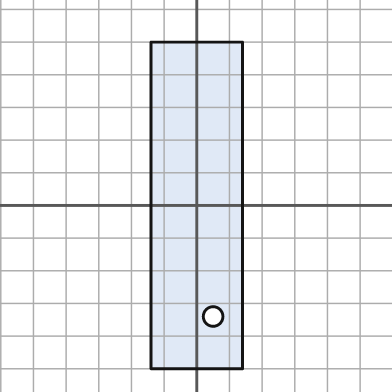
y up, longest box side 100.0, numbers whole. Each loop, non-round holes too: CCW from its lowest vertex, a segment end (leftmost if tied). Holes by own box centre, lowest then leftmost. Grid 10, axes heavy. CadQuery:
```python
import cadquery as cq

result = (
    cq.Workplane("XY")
    .moveTo(-14.0, -50.0)
    .lineTo(14.0, -50.0)
    .lineTo(14.0, 50.0)
    .lineTo(-14.0, 50.0)
    .close()
    .moveTo(5.0, -34.0)
    .circle(3.0)
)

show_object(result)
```